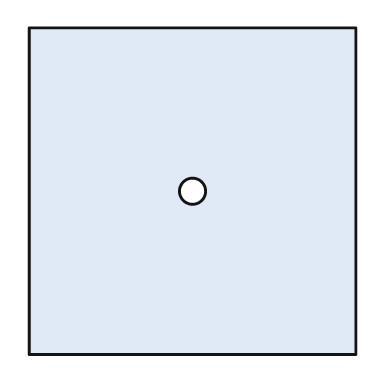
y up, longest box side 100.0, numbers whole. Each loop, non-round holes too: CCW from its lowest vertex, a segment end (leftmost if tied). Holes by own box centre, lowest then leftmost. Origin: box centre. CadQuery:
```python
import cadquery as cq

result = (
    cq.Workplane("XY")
    .moveTo(-50.0, -50.0)
    .lineTo(50.0, -50.0)
    .lineTo(50.0, 50.0)
    .lineTo(-50.0, 50.0)
    .close()
    .moveTo(0.0, 0.0)
    .circle(4.0)
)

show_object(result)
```